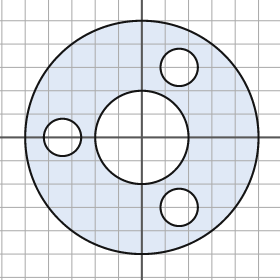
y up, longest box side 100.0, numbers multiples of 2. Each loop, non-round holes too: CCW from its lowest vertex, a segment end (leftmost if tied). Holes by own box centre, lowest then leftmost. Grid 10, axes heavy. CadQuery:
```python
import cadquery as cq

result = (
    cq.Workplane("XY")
    .moveTo(0.0, 0.0)
    .circle(50.0)
    .moveTo(16.0, -30.0)
    .circle(8.0)
    .moveTo(-34.0, 0.0)
    .circle(8.0)
    .moveTo(0.0, 0.0)
    .circle(20.0)
    .moveTo(16.0, 30.0)
    .circle(8.0)
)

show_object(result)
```